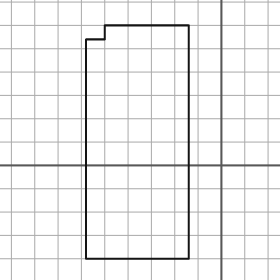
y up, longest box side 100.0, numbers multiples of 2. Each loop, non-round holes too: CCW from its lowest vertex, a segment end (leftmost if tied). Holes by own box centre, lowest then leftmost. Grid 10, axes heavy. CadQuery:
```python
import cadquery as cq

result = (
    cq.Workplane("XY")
    .moveTo(-58.0, -40.0)
    .lineTo(-14.0, -40.0)
    .lineTo(-14.0, 60.0)
    .lineTo(-50.0, 60.0)
    .lineTo(-50.0, 54.0)
    .lineTo(-58.0, 54.0)
    .close()
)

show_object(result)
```